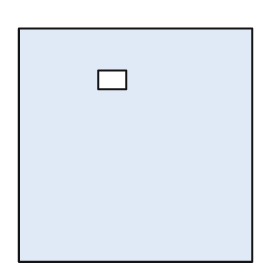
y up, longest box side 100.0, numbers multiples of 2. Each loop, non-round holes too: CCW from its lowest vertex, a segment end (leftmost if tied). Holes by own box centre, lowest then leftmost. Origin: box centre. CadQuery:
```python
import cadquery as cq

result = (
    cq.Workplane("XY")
    .moveTo(-50.0, -50.0)
    .lineTo(50.0, -50.0)
    .lineTo(50.0, 50.0)
    .lineTo(-50.0, 50.0)
    .close()
    .moveTo(-16.0, 24.0)
    .lineTo(-4.0, 24.0)
    .lineTo(-4.0, 32.0)
    .lineTo(-16.0, 32.0)
    .close()
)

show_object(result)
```